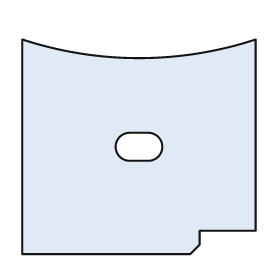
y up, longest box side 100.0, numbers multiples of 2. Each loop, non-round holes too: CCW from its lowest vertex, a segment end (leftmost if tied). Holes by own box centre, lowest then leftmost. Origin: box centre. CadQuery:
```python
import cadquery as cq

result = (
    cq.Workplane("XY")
    .moveTo(-50.0, -46.0)
    .lineTo(22.0, -46.0)
    .lineTo(26.0, -42.0)
    .lineTo(26.0, -36.0)
    .lineTo(50.0, -36.0)
    .lineTo(50.0, 46.0)
    .threePointArc((0.0, 38.0), (-50.0, 46.0))
    .close()
    .moveTo(-4.0, -6.0)
    .lineTo(4.0, -6.0)
    .threePointArc((10.0, 0.0), (4.0, 6.0))
    .lineTo(-4.0, 6.0)
    .threePointArc((-10.0, 0.0), (-4.0, -6.0))
    .close()
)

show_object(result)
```